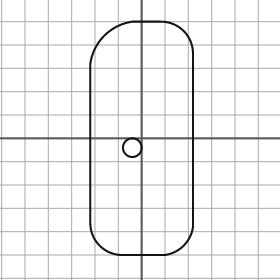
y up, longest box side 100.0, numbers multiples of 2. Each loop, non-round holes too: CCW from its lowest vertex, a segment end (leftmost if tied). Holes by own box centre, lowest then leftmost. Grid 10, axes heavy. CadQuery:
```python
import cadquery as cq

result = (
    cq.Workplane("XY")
    .moveTo(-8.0, -50.0)
    .lineTo(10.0, -50.0)
    .threePointArc((18.0, -46.0), (22.0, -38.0))
    .lineTo(22.0, 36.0)
    .threePointArc((18.0, 46.0), (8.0, 50.0))
    .lineTo(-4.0, 50.0)
    .threePointArc((-16.0, 44.0), (-22.0, 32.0))
    .lineTo(-22.0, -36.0)
    .threePointArc((-18.0, -46.0), (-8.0, -50.0))
    .close()
    .moveTo(-4.0, -4.0)
    .circle(4.0)
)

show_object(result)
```